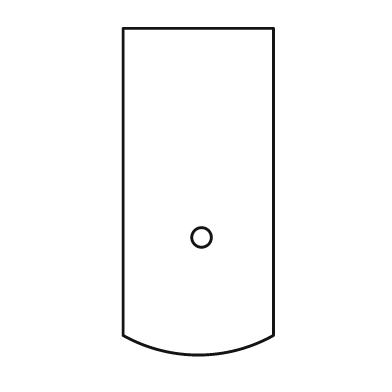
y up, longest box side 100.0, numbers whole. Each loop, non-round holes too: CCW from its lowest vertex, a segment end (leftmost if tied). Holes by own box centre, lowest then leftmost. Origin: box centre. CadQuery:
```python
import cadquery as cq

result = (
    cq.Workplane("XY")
    .moveTo(-23.0, -44.0)
    .threePointArc((0.0, -50.0), (23.0, -44.0))
    .lineTo(23.0, 50.0)
    .lineTo(-23.0, 50.0)
    .close()
    .moveTo(1.0, -14.0)
    .circle(3.0)
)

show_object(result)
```